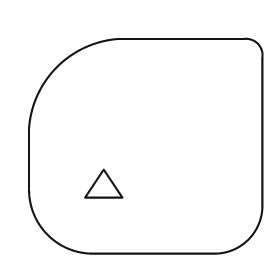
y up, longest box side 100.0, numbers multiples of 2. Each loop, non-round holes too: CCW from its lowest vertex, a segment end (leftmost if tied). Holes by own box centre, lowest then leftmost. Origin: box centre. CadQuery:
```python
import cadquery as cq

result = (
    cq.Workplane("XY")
    .moveTo(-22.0, -46.0)
    .lineTo(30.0, -46.0)
    .threePointArc((44.0, -40.0), (50.0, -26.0))
    .lineTo(50.0, 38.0)
    .threePointArc((48.0, 44.0), (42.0, 46.0))
    .lineTo(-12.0, 46.0)
    .threePointArc((-38.0, 34.0), (-50.0, 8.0))
    .lineTo(-50.0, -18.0)
    .threePointArc((-42.0, -38.0), (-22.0, -46.0))
    .close()
    .moveTo(-26.0, -22.0)
    .lineTo(-10.0, -22.0)
    .lineTo(-18.0, -10.0)
    .close()
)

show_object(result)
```